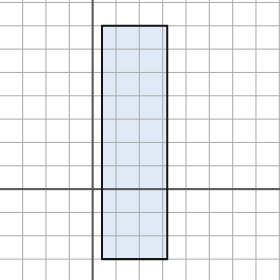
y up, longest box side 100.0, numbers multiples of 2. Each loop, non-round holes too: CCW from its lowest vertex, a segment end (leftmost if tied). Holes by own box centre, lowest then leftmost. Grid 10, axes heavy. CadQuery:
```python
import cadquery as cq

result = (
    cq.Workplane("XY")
    .moveTo(4.0, -30.0)
    .lineTo(32.0, -30.0)
    .lineTo(32.0, 70.0)
    .lineTo(4.0, 70.0)
    .close()
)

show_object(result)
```